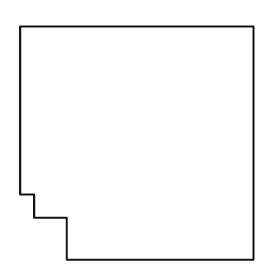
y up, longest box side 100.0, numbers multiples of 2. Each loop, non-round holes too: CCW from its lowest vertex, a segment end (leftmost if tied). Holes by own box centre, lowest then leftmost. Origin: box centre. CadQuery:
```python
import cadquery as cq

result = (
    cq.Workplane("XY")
    .moveTo(-30.0, -50.0)
    .lineTo(50.0, -50.0)
    .lineTo(50.0, 50.0)
    .lineTo(-50.0, 50.0)
    .lineTo(-50.0, -22.0)
    .lineTo(-44.0, -22.0)
    .lineTo(-44.0, -32.0)
    .lineTo(-30.0, -32.0)
    .close()
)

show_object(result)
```